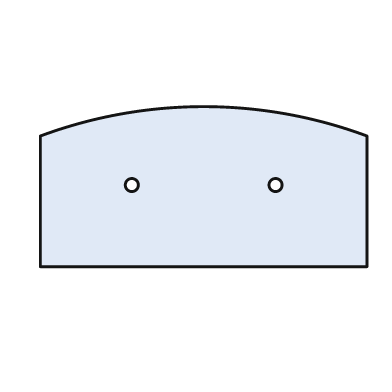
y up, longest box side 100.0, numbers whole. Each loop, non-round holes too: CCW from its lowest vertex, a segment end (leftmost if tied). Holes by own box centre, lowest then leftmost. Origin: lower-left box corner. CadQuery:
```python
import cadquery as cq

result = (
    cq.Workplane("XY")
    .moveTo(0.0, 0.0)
    .lineTo(100.0, 0.0)
    .lineTo(100.0, 40.0)
    .threePointArc((50.0, 49.0), (0.0, 40.0))
    .close()
    .moveTo(28.0, 25.0)
    .circle(2.0)
    .moveTo(72.0, 25.0)
    .circle(2.0)
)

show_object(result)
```